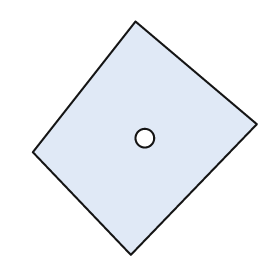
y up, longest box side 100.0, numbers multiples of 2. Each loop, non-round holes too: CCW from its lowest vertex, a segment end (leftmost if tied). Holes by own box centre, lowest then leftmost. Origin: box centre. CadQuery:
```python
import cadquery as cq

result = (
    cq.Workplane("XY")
    .moveTo(-6.0, -50.0)
    .lineTo(48.0, 6.0)
    .lineTo(-4.0, 50.0)
    .lineTo(-48.0, -6.0)
    .close()
    .moveTo(0.0, 0.0)
    .circle(4.0)
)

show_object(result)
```